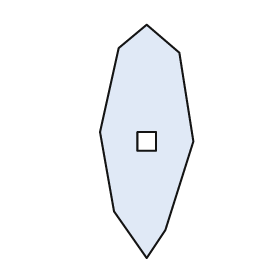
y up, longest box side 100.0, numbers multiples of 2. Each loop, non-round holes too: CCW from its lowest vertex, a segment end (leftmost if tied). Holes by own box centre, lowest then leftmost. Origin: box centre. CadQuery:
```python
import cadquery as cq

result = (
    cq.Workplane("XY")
    .moveTo(0.0, -50.0)
    .lineTo(8.0, -38.0)
    .lineTo(20.0, 0.0)
    .lineTo(14.0, 38.0)
    .lineTo(0.0, 50.0)
    .lineTo(-12.0, 40.0)
    .lineTo(-20.0, 4.0)
    .lineTo(-14.0, -30.0)
    .close()
    .moveTo(-4.0, -4.0)
    .lineTo(4.0, -4.0)
    .lineTo(4.0, 4.0)
    .lineTo(-4.0, 4.0)
    .close()
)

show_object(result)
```